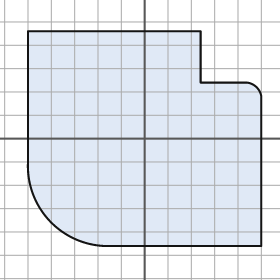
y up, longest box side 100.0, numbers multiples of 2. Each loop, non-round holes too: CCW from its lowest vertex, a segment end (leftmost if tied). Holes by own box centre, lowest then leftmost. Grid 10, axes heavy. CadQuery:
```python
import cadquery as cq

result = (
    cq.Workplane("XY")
    .moveTo(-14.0, -46.0)
    .lineTo(50.0, -46.0)
    .lineTo(50.0, 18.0)
    .threePointArc((48.0, 22.0), (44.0, 24.0))
    .lineTo(24.0, 24.0)
    .lineTo(24.0, 46.0)
    .lineTo(-50.0, 46.0)
    .lineTo(-50.0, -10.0)
    .threePointArc((-40.0, -36.0), (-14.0, -46.0))
    .close()
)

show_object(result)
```